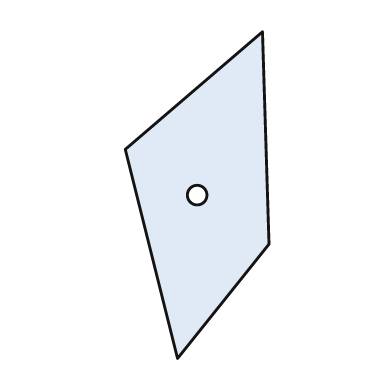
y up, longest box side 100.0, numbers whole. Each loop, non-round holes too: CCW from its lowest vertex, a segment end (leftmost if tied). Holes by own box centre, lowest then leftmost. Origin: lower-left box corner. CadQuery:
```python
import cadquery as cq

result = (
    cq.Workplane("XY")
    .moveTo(16.0, 0.0)
    .lineTo(44.0, 35.0)
    .lineTo(42.0, 100.0)
    .lineTo(0.0, 64.0)
    .close()
    .moveTo(22.0, 50.0)
    .circle(3.0)
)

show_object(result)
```